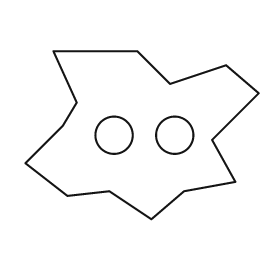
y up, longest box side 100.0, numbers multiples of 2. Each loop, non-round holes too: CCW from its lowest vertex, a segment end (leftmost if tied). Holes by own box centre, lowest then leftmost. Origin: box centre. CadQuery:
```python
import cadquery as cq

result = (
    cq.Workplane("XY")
    .moveTo(4.0, -36.0)
    .lineTo(18.0, -24.0)
    .lineTo(40.0, -20.0)
    .lineTo(30.0, -2.0)
    .lineTo(50.0, 18.0)
    .lineTo(36.0, 30.0)
    .lineTo(12.0, 22.0)
    .lineTo(-2.0, 36.0)
    .lineTo(-38.0, 36.0)
    .lineTo(-28.0, 14.0)
    .lineTo(-34.0, 4.0)
    .lineTo(-50.0, -12.0)
    .lineTo(-32.0, -26.0)
    .lineTo(-14.0, -24.0)
    .close()
    .moveTo(-12.0, 0.0)
    .circle(8.0)
    .moveTo(14.0, 0.0)
    .circle(8.0)
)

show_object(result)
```